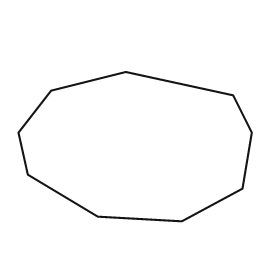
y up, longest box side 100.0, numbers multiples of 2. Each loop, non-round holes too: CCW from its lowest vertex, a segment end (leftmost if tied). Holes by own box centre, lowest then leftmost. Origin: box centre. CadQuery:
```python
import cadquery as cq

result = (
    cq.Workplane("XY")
    .moveTo(20.0, -32.0)
    .lineTo(46.0, -18.0)
    .lineTo(50.0, 6.0)
    .lineTo(42.0, 22.0)
    .lineTo(-4.0, 32.0)
    .lineTo(-36.0, 24.0)
    .lineTo(-50.0, 6.0)
    .lineTo(-46.0, -12.0)
    .lineTo(-16.0, -30.0)
    .close()
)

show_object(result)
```